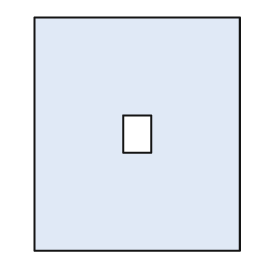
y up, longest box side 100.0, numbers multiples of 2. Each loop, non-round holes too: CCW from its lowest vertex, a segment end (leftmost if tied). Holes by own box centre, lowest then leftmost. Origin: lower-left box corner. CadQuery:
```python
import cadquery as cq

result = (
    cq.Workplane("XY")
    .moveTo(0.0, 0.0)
    .lineTo(88.0, 0.0)
    .lineTo(88.0, 100.0)
    .lineTo(0.0, 100.0)
    .close()
    .moveTo(38.0, 42.0)
    .lineTo(50.0, 42.0)
    .lineTo(50.0, 58.0)
    .lineTo(38.0, 58.0)
    .close()
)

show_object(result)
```